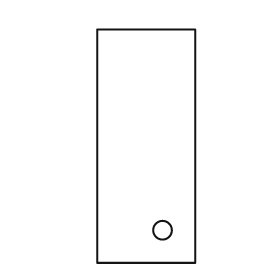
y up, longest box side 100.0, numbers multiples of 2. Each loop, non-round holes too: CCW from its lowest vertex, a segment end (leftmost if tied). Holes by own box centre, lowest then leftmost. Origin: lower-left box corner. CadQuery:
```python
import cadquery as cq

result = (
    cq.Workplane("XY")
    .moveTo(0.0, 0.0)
    .lineTo(42.0, 0.0)
    .lineTo(42.0, 100.0)
    .lineTo(0.0, 100.0)
    .close()
    .moveTo(28.0, 14.0)
    .circle(4.0)
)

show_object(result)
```